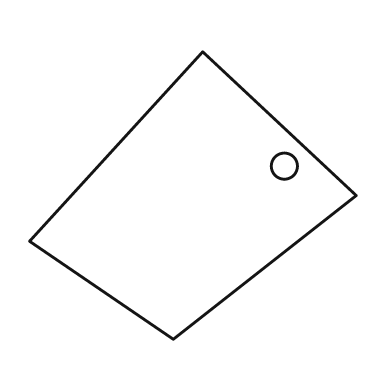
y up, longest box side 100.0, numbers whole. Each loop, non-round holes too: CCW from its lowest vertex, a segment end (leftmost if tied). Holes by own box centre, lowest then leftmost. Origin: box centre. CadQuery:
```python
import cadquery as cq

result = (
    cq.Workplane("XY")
    .moveTo(-6.0, -44.0)
    .lineTo(50.0, 0.0)
    .lineTo(3.0, 44.0)
    .lineTo(-50.0, -14.0)
    .close()
    .moveTo(28.0, 9.0)
    .circle(4.0)
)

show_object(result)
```